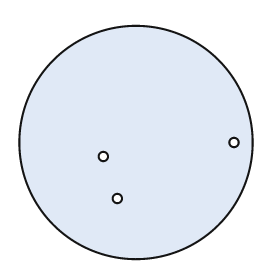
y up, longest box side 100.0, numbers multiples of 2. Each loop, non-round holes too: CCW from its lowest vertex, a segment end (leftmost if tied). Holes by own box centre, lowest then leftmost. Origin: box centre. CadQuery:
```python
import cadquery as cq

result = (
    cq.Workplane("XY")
    .moveTo(0.0, 0.0)
    .circle(50.0)
    .moveTo(-8.0, -24.0)
    .circle(2.0)
    .moveTo(-14.0, -6.0)
    .circle(2.0)
    .moveTo(42.0, 0.0)
    .circle(2.0)
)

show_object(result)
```